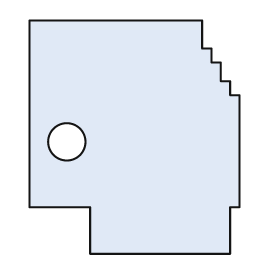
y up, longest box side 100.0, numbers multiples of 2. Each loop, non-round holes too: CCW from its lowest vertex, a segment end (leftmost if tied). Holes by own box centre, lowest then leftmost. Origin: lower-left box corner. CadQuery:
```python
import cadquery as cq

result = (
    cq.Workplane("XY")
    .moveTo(26.0, 0.0)
    .lineTo(86.0, 0.0)
    .lineTo(86.0, 20.0)
    .lineTo(90.0, 20.0)
    .lineTo(90.0, 68.0)
    .lineTo(86.0, 68.0)
    .lineTo(86.0, 74.0)
    .lineTo(82.0, 74.0)
    .lineTo(82.0, 82.0)
    .lineTo(78.0, 82.0)
    .lineTo(78.0, 88.0)
    .lineTo(74.0, 88.0)
    .lineTo(74.0, 100.0)
    .lineTo(0.0, 100.0)
    .lineTo(0.0, 20.0)
    .lineTo(26.0, 20.0)
    .close()
    .moveTo(16.0, 48.0)
    .circle(8.0)
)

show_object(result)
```